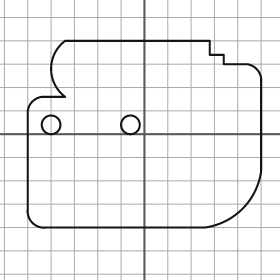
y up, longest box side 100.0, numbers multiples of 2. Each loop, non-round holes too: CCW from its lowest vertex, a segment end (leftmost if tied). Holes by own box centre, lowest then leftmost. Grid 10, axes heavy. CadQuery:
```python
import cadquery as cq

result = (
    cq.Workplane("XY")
    .moveTo(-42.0, -40.0)
    .lineTo(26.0, -40.0)
    .threePointArc((42.0, -32.0), (50.0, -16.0))
    .lineTo(50.0, 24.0)
    .threePointArc((48.0, 28.0), (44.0, 30.0))
    .lineTo(34.0, 30.0)
    .lineTo(34.0, 34.0)
    .lineTo(28.0, 34.0)
    .lineTo(28.0, 40.0)
    .lineTo(-34.0, 40.0)
    .threePointArc((-40.0, 28.0), (-34.0, 16.0))
    .lineTo(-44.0, 16.0)
    .threePointArc((-48.0, 14.0), (-50.0, 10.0))
    .lineTo(-50.0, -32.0)
    .threePointArc((-48.0, -38.0), (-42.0, -40.0))
    .close()
    .moveTo(-40.0, 4.0)
    .circle(4.0)
    .moveTo(-6.0, 4.0)
    .circle(4.0)
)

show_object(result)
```